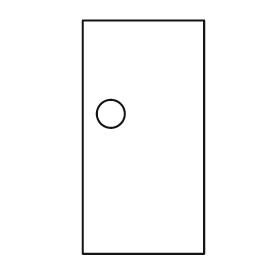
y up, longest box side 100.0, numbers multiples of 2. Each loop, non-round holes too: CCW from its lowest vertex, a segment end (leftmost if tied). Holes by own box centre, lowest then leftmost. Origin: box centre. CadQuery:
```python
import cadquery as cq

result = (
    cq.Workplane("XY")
    .moveTo(-26.0, -50.0)
    .lineTo(26.0, -50.0)
    .lineTo(26.0, 50.0)
    .lineTo(-26.0, 50.0)
    .close()
    .moveTo(-14.0, 10.0)
    .circle(6.0)
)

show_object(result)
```